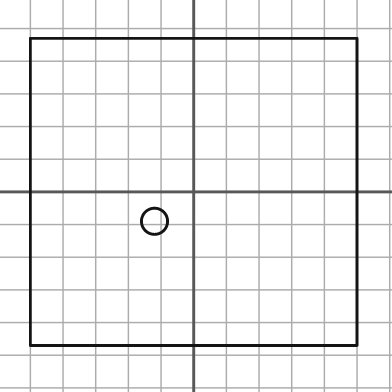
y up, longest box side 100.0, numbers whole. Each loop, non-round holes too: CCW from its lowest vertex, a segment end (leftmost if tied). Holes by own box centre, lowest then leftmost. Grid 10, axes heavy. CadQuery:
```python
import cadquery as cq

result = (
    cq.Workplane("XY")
    .moveTo(-50.0, -47.0)
    .lineTo(50.0, -47.0)
    .lineTo(50.0, 47.0)
    .lineTo(-50.0, 47.0)
    .close()
    .moveTo(-12.0, -9.0)
    .circle(4.0)
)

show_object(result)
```